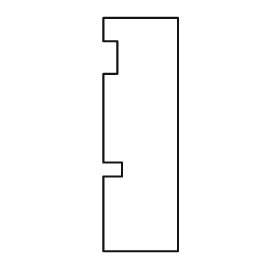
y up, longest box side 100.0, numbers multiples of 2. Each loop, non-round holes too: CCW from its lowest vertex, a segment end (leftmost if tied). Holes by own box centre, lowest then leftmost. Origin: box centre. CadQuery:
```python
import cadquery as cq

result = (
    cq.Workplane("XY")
    .moveTo(-16.0, -50.0)
    .lineTo(16.0, -50.0)
    .lineTo(16.0, 50.0)
    .lineTo(-16.0, 50.0)
    .lineTo(-16.0, 40.0)
    .lineTo(-10.0, 40.0)
    .lineTo(-10.0, 26.0)
    .lineTo(-16.0, 26.0)
    .lineTo(-16.0, -12.0)
    .lineTo(-8.0, -12.0)
    .lineTo(-8.0, -18.0)
    .lineTo(-16.0, -18.0)
    .close()
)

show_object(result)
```